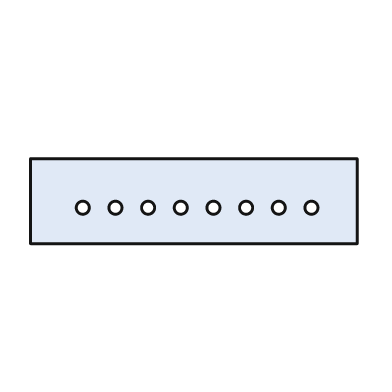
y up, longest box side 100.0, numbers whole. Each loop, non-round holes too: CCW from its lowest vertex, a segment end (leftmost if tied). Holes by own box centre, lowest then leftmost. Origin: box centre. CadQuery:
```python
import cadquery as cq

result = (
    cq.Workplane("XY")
    .moveTo(-50.0, -13.0)
    .lineTo(50.0, -13.0)
    .lineTo(50.0, 13.0)
    .lineTo(-50.0, 13.0)
    .close()
    .moveTo(-34.0, -2.0)
    .circle(2.0)
    .moveTo(-24.0, -2.0)
    .circle(2.0)
    .moveTo(-14.0, -2.0)
    .circle(2.0)
    .moveTo(-4.0, -2.0)
    .circle(2.0)
    .moveTo(6.0, -2.0)
    .circle(2.0)
    .moveTo(16.0, -2.0)
    .circle(2.0)
    .moveTo(26.0, -2.0)
    .circle(2.0)
    .moveTo(36.0, -2.0)
    .circle(2.0)
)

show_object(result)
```